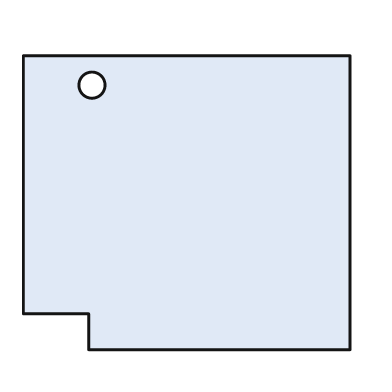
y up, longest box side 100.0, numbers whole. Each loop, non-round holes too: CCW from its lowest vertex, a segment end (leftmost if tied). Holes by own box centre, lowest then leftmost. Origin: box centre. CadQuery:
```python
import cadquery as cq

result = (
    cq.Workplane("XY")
    .moveTo(-30.0, -45.0)
    .lineTo(50.0, -45.0)
    .lineTo(50.0, 45.0)
    .lineTo(-50.0, 45.0)
    .lineTo(-50.0, -34.0)
    .lineTo(-30.0, -34.0)
    .close()
    .moveTo(-29.0, 36.0)
    .circle(4.0)
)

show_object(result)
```